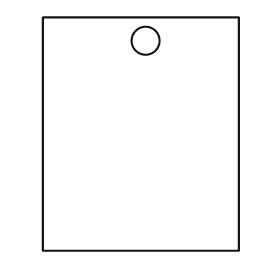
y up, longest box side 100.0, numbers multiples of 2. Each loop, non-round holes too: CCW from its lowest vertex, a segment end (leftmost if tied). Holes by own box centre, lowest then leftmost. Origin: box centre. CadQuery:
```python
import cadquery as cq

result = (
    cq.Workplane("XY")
    .moveTo(-42.0, -50.0)
    .lineTo(42.0, -50.0)
    .lineTo(42.0, 50.0)
    .lineTo(-42.0, 50.0)
    .close()
    .moveTo(2.0, 40.0)
    .circle(6.0)
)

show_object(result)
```